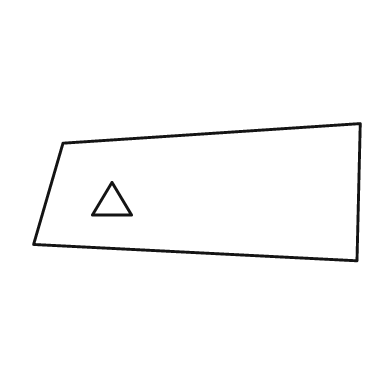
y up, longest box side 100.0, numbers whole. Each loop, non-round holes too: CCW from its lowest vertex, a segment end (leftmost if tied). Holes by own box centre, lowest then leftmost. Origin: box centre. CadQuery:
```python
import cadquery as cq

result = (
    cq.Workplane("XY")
    .moveTo(49.0, -21.0)
    .lineTo(50.0, 21.0)
    .lineTo(-41.0, 15.0)
    .lineTo(-50.0, -16.0)
    .close()
    .moveTo(-32.0, -7.0)
    .lineTo(-20.0, -7.0)
    .lineTo(-26.0, 3.0)
    .close()
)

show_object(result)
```